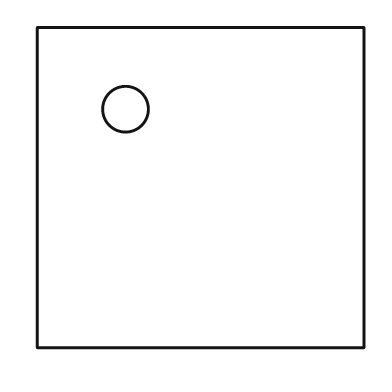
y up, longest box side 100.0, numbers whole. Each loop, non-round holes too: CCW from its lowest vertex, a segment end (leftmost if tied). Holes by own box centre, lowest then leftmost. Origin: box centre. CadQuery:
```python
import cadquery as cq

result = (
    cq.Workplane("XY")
    .moveTo(-50.0, -49.0)
    .lineTo(50.0, -49.0)
    .lineTo(50.0, 49.0)
    .lineTo(-50.0, 49.0)
    .close()
    .moveTo(-23.0, 24.0)
    .circle(7.0)
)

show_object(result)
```